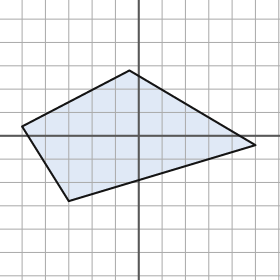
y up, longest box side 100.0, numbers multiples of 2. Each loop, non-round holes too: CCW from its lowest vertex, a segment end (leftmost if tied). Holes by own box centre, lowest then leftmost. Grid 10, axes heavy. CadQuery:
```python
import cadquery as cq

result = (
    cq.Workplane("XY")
    .moveTo(-30.0, -28.0)
    .lineTo(50.0, -4.0)
    .lineTo(-4.0, 28.0)
    .lineTo(-50.0, 4.0)
    .close()
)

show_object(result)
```